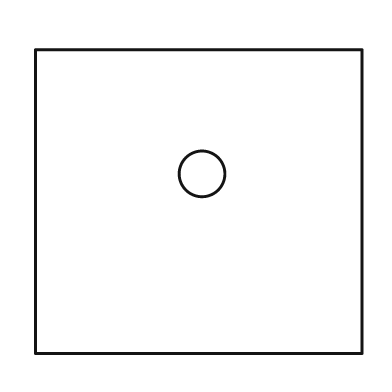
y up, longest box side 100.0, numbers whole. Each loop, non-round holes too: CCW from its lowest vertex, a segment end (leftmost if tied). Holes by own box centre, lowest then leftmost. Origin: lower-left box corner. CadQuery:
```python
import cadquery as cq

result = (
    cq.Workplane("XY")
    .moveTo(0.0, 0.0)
    .lineTo(100.0, 0.0)
    .lineTo(100.0, 93.0)
    .lineTo(0.0, 93.0)
    .close()
    .moveTo(51.0, 55.0)
    .circle(7.0)
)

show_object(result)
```